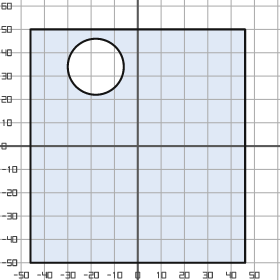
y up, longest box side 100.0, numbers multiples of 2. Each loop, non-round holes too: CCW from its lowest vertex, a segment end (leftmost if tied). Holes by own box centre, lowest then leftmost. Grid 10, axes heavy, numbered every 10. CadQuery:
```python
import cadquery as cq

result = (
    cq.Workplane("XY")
    .moveTo(-46.0, -50.0)
    .lineTo(46.0, -50.0)
    .lineTo(46.0, 50.0)
    .lineTo(-46.0, 50.0)
    .close()
    .moveTo(-18.0, 34.0)
    .circle(12.0)
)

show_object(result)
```